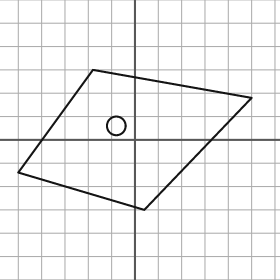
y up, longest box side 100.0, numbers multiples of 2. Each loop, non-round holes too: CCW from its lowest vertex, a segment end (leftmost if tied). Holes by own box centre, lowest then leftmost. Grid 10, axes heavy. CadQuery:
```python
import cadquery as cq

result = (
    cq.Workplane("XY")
    .moveTo(4.0, -30.0)
    .lineTo(50.0, 18.0)
    .lineTo(-18.0, 30.0)
    .lineTo(-50.0, -14.0)
    .close()
    .moveTo(-8.0, 6.0)
    .circle(4.0)
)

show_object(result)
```